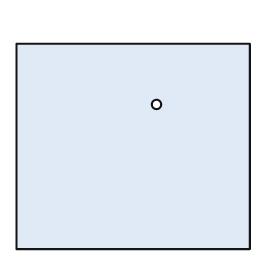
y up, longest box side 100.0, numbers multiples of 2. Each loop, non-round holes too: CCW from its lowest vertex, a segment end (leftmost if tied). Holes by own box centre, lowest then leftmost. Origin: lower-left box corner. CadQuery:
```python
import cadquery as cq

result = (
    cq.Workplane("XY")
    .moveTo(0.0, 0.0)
    .lineTo(100.0, 0.0)
    .lineTo(100.0, 88.0)
    .lineTo(0.0, 88.0)
    .close()
    .moveTo(60.0, 62.0)
    .circle(2.0)
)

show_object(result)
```